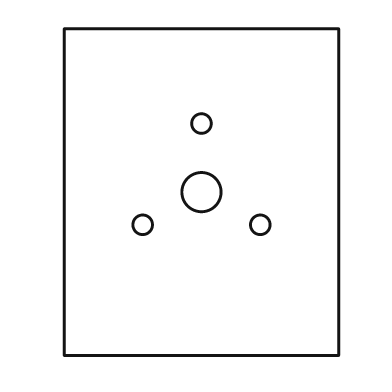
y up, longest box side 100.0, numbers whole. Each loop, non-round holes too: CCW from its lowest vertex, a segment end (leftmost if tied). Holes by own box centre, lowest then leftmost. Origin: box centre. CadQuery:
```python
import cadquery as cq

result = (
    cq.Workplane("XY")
    .moveTo(-42.0, -50.0)
    .lineTo(42.0, -50.0)
    .lineTo(42.0, 50.0)
    .lineTo(-42.0, 50.0)
    .close()
    .moveTo(-18.0, -10.0)
    .circle(3.0)
    .moveTo(18.0, -10.0)
    .circle(3.0)
    .moveTo(0.0, 0.0)
    .circle(6.0)
    .moveTo(0.0, 21.0)
    .circle(3.0)
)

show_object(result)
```